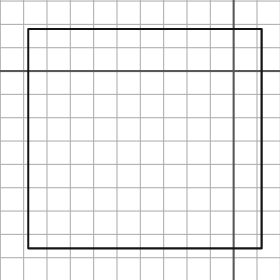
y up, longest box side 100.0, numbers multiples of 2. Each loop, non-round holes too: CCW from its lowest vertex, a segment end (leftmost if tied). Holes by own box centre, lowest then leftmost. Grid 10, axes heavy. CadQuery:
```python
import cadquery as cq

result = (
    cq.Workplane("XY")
    .moveTo(-88.0, -76.0)
    .lineTo(12.0, -76.0)
    .lineTo(12.0, 18.0)
    .lineTo(-88.0, 18.0)
    .close()
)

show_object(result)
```